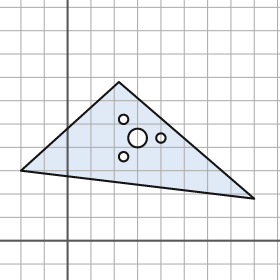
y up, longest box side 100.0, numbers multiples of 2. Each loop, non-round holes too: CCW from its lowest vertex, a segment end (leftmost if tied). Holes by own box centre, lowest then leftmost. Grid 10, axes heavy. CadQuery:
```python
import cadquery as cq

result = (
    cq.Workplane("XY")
    .moveTo(80.0, 18.0)
    .lineTo(22.0, 68.0)
    .lineTo(-20.0, 30.0)
    .close()
    .moveTo(24.0, 36.0)
    .circle(2.0)
    .moveTo(30.0, 44.0)
    .circle(4.0)
    .moveTo(40.0, 44.0)
    .circle(2.0)
    .moveTo(24.0, 52.0)
    .circle(2.0)
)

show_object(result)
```